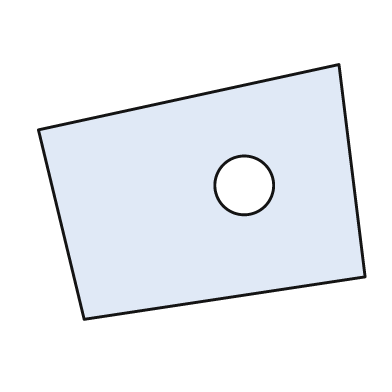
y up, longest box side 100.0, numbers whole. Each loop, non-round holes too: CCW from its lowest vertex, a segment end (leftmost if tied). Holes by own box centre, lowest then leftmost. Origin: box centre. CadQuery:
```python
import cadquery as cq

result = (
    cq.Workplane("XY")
    .moveTo(-36.0, -39.0)
    .lineTo(50.0, -26.0)
    .lineTo(42.0, 39.0)
    .lineTo(-50.0, 19.0)
    .close()
    .moveTo(13.0, 2.0)
    .circle(9.0)
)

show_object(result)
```